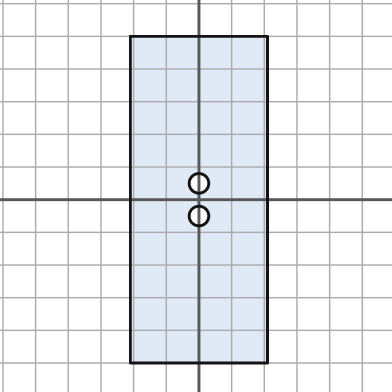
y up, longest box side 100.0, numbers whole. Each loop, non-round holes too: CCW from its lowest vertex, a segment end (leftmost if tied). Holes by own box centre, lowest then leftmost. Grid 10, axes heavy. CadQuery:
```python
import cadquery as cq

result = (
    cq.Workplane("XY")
    .moveTo(-21.0, -50.0)
    .lineTo(21.0, -50.0)
    .lineTo(21.0, 50.0)
    .lineTo(-21.0, 50.0)
    .close()
    .moveTo(0.0, -5.0)
    .circle(3.0)
    .moveTo(0.0, 5.0)
    .circle(3.0)
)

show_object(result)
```